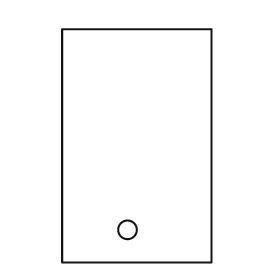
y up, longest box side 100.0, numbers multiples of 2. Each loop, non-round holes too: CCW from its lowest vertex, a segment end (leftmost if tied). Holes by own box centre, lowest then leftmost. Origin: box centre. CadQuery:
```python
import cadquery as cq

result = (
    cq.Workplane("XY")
    .moveTo(-32.0, -50.0)
    .lineTo(32.0, -50.0)
    .lineTo(32.0, 50.0)
    .lineTo(-32.0, 50.0)
    .close()
    .moveTo(-4.0, -36.0)
    .circle(4.0)
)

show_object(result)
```